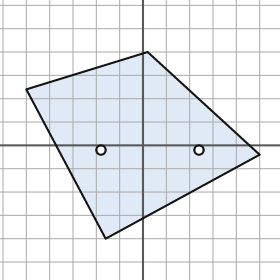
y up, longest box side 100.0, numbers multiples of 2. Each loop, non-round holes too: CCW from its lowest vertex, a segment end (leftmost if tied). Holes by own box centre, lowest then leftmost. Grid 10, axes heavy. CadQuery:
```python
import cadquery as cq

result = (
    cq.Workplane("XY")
    .moveTo(-16.0, -40.0)
    .lineTo(50.0, -4.0)
    .lineTo(2.0, 40.0)
    .lineTo(-50.0, 24.0)
    .close()
    .moveTo(-18.0, -2.0)
    .circle(2.0)
    .moveTo(24.0, -2.0)
    .circle(2.0)
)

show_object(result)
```